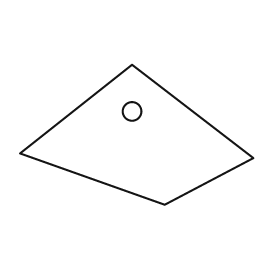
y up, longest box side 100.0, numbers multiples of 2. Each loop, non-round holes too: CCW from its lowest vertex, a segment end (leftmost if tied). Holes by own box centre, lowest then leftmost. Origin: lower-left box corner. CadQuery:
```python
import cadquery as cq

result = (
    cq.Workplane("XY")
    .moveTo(62.0, 0.0)
    .lineTo(100.0, 20.0)
    .lineTo(48.0, 60.0)
    .lineTo(0.0, 22.0)
    .close()
    .moveTo(48.0, 40.0)
    .circle(4.0)
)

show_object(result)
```